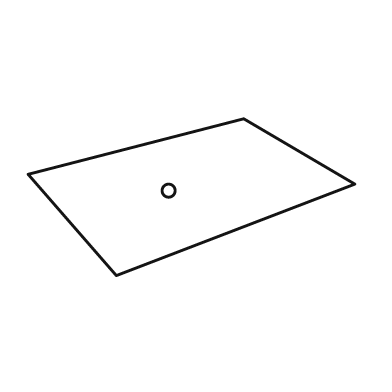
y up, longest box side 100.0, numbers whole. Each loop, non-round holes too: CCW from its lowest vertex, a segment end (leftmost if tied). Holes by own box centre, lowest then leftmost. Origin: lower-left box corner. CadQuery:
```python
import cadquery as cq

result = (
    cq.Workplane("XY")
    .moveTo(27.0, 0.0)
    .lineTo(100.0, 28.0)
    .lineTo(66.0, 48.0)
    .lineTo(0.0, 31.0)
    .close()
    .moveTo(43.0, 26.0)
    .circle(2.0)
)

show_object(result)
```